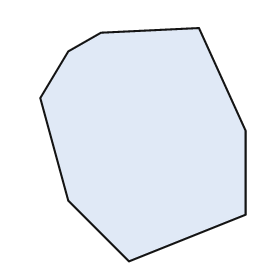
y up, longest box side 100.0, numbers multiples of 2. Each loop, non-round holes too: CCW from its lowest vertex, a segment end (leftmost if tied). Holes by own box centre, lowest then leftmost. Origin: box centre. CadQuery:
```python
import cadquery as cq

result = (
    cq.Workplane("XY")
    .moveTo(-6.0, -50.0)
    .lineTo(44.0, -30.0)
    .lineTo(44.0, 6.0)
    .lineTo(24.0, 50.0)
    .lineTo(-18.0, 48.0)
    .lineTo(-32.0, 40.0)
    .lineTo(-44.0, 20.0)
    .lineTo(-32.0, -24.0)
    .close()
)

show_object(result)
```